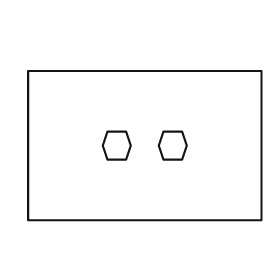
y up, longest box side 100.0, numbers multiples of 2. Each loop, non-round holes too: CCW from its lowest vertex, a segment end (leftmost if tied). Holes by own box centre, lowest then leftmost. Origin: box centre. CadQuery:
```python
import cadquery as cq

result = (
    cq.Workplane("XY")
    .moveTo(-50.0, -32.0)
    .lineTo(50.0, -32.0)
    .lineTo(50.0, 32.0)
    .lineTo(-50.0, 32.0)
    .close()
    .moveTo(-16.0, -6.0)
    .lineTo(-8.0, -6.0)
    .lineTo(-6.0, 0.0)
    .lineTo(-8.0, 6.0)
    .lineTo(-16.0, 6.0)
    .lineTo(-18.0, 0.0)
    .close()
    .moveTo(8.0, -6.0)
    .lineTo(16.0, -6.0)
    .lineTo(18.0, 0.0)
    .lineTo(16.0, 6.0)
    .lineTo(8.0, 6.0)
    .lineTo(6.0, 0.0)
    .close()
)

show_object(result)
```